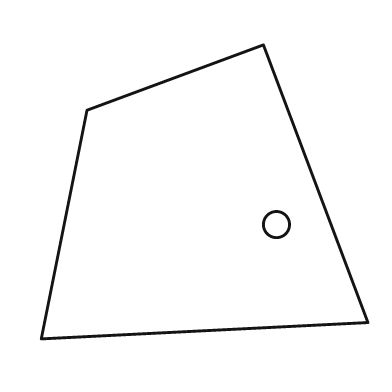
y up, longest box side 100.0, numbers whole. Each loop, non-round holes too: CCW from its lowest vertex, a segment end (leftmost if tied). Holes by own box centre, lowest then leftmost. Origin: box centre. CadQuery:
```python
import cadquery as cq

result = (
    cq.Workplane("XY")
    .moveTo(-50.0, -45.0)
    .lineTo(50.0, -40.0)
    .lineTo(18.0, 45.0)
    .lineTo(-36.0, 25.0)
    .close()
    .moveTo(22.0, -10.0)
    .circle(4.0)
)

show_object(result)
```